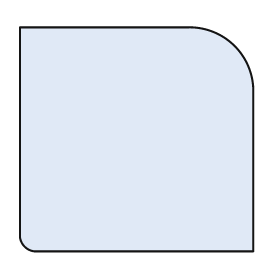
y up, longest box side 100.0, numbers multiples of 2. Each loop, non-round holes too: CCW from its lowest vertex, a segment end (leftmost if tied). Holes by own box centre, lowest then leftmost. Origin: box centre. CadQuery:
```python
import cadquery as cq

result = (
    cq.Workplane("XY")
    .moveTo(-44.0, -48.0)
    .lineTo(50.0, -48.0)
    .lineTo(50.0, 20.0)
    .threePointArc((42.0, 40.0), (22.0, 48.0))
    .lineTo(-50.0, 48.0)
    .lineTo(-50.0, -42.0)
    .threePointArc((-48.0, -46.0), (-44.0, -48.0))
    .close()
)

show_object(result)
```